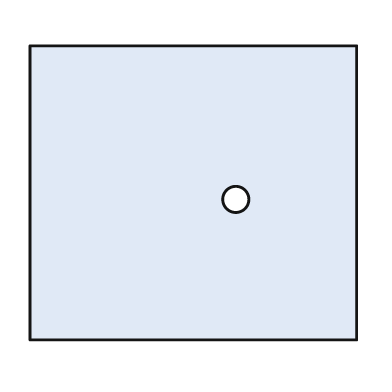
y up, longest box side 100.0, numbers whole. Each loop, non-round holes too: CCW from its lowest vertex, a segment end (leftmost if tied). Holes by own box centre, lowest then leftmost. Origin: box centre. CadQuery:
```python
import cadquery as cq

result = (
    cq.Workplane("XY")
    .moveTo(-50.0, -45.0)
    .lineTo(50.0, -45.0)
    .lineTo(50.0, 45.0)
    .lineTo(-50.0, 45.0)
    .close()
    .moveTo(13.0, -2.0)
    .circle(4.0)
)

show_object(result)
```